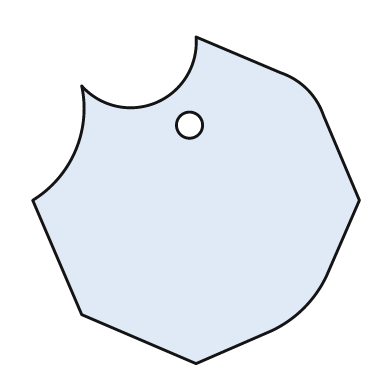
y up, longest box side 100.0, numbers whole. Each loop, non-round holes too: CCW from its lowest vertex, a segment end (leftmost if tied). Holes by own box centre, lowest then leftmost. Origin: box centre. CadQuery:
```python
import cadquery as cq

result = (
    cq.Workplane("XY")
    .moveTo(0.0, -50.0)
    .lineTo(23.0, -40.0)
    .threePointArc((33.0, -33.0), (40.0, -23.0))
    .lineTo(50.0, 0.0)
    .lineTo(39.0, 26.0)
    .threePointArc((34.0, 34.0), (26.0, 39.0))
    .lineTo(0.0, 50.0)
    .threePointArc((-12.0, 30.0), (-35.0, 35.0))
    .threePointArc((-37.0, 15.0), (-50.0, 0.0))
    .lineTo(-35.0, -35.0)
    .close()
    .moveTo(-2.0, 23.0)
    .circle(4.0)
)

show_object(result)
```